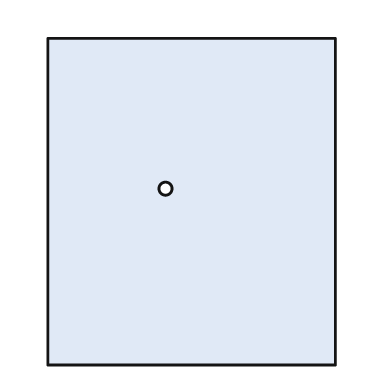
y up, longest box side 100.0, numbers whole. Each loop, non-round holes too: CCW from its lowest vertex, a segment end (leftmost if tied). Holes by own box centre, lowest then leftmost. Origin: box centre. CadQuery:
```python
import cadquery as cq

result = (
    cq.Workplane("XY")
    .moveTo(-44.0, -50.0)
    .lineTo(44.0, -50.0)
    .lineTo(44.0, 50.0)
    .lineTo(-44.0, 50.0)
    .close()
    .moveTo(-8.0, 4.0)
    .circle(2.0)
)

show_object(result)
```